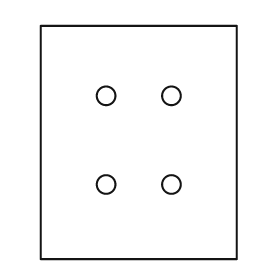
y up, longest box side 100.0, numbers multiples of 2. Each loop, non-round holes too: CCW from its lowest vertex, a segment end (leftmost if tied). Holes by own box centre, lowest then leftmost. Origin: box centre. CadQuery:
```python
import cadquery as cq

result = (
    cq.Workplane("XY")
    .moveTo(-42.0, -50.0)
    .lineTo(42.0, -50.0)
    .lineTo(42.0, 50.0)
    .lineTo(-42.0, 50.0)
    .close()
    .moveTo(-14.0, -18.0)
    .circle(4.0)
    .moveTo(14.0, -18.0)
    .circle(4.0)
    .moveTo(-14.0, 20.0)
    .circle(4.0)
    .moveTo(14.0, 20.0)
    .circle(4.0)
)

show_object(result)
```